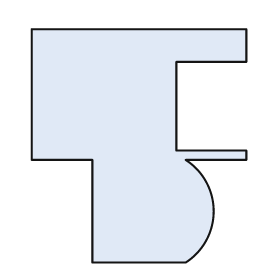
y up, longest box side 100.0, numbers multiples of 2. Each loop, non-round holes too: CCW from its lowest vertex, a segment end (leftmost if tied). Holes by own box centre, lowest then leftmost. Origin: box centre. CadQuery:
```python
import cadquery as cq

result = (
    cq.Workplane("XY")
    .moveTo(-20.0, -50.0)
    .lineTo(20.0, -50.0)
    .threePointArc((32.0, -28.0), (20.0, -6.0))
    .lineTo(46.0, -6.0)
    .lineTo(46.0, -2.0)
    .lineTo(16.0, -2.0)
    .lineTo(16.0, 36.0)
    .lineTo(46.0, 36.0)
    .lineTo(46.0, 50.0)
    .lineTo(-46.0, 50.0)
    .lineTo(-46.0, -6.0)
    .lineTo(-20.0, -6.0)
    .close()
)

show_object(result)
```